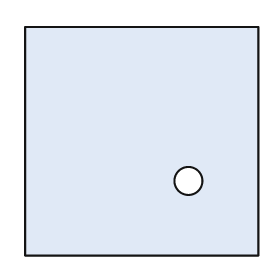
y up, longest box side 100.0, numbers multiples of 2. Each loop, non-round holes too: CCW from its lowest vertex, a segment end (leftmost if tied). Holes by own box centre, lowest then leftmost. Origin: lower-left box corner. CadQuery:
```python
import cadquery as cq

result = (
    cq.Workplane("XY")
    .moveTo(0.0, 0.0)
    .lineTo(100.0, 0.0)
    .lineTo(100.0, 98.0)
    .lineTo(0.0, 98.0)
    .close()
    .moveTo(70.0, 32.0)
    .circle(6.0)
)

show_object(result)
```